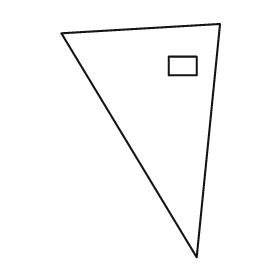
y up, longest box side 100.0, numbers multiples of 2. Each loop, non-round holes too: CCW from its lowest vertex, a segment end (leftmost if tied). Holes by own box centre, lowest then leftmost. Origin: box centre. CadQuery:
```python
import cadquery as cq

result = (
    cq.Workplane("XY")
    .moveTo(24.0, -50.0)
    .lineTo(34.0, 50.0)
    .lineTo(-34.0, 46.0)
    .close()
    .moveTo(12.0, 28.0)
    .lineTo(24.0, 28.0)
    .lineTo(24.0, 36.0)
    .lineTo(12.0, 36.0)
    .close()
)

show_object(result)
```